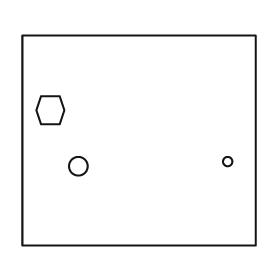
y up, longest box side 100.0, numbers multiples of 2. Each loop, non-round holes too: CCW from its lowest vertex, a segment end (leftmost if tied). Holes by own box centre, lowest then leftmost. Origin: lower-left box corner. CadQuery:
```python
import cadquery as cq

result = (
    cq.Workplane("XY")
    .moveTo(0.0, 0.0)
    .lineTo(100.0, 0.0)
    .lineTo(100.0, 90.0)
    .lineTo(0.0, 90.0)
    .close()
    .moveTo(24.0, 34.0)
    .circle(4.0)
    .moveTo(88.0, 36.0)
    .circle(2.0)
    .moveTo(8.0, 52.0)
    .lineTo(16.0, 52.0)
    .lineTo(18.0, 58.0)
    .lineTo(16.0, 64.0)
    .lineTo(8.0, 64.0)
    .lineTo(6.0, 58.0)
    .close()
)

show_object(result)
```